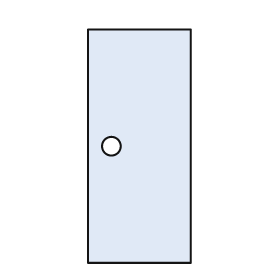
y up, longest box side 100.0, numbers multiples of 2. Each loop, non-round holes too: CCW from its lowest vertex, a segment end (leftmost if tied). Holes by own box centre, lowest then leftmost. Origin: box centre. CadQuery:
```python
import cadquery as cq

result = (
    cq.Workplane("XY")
    .moveTo(-22.0, -50.0)
    .lineTo(22.0, -50.0)
    .lineTo(22.0, 50.0)
    .lineTo(-22.0, 50.0)
    .close()
    .moveTo(-12.0, 0.0)
    .circle(4.0)
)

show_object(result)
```